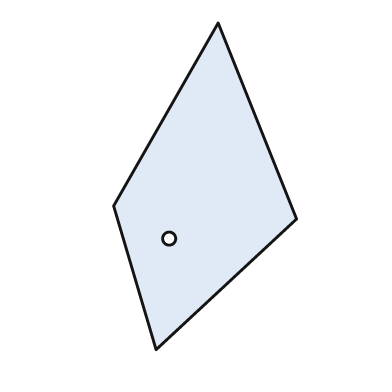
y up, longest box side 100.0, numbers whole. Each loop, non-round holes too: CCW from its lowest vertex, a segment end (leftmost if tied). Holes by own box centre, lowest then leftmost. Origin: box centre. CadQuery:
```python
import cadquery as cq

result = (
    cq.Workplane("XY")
    .moveTo(-15.0, -50.0)
    .lineTo(28.0, -10.0)
    .lineTo(4.0, 50.0)
    .lineTo(-28.0, -6.0)
    .close()
    .moveTo(-11.0, -16.0)
    .circle(2.0)
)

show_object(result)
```